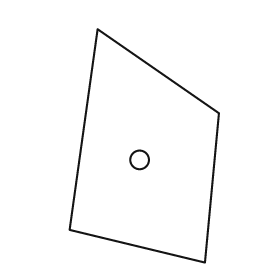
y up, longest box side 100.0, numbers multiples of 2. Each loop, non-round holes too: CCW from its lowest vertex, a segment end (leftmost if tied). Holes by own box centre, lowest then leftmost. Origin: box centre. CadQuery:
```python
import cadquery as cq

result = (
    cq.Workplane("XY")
    .moveTo(26.0, -50.0)
    .lineTo(32.0, 14.0)
    .lineTo(-20.0, 50.0)
    .lineTo(-32.0, -36.0)
    .close()
    .moveTo(-2.0, -6.0)
    .circle(4.0)
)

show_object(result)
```